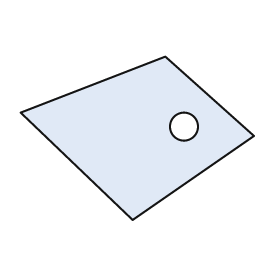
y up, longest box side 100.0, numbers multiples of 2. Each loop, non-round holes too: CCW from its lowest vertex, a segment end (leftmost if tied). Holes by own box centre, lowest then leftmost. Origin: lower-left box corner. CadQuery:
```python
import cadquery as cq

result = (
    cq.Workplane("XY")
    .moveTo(48.0, 0.0)
    .lineTo(100.0, 36.0)
    .lineTo(62.0, 70.0)
    .lineTo(0.0, 46.0)
    .close()
    .moveTo(70.0, 40.0)
    .circle(6.0)
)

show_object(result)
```